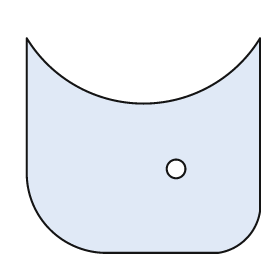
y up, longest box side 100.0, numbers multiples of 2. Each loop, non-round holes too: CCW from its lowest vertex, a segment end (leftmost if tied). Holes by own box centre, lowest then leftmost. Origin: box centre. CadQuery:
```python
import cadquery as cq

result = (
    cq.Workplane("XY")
    .moveTo(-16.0, -46.0)
    .lineTo(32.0, -46.0)
    .threePointArc((44.0, -40.0), (50.0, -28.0))
    .lineTo(50.0, 46.0)
    .threePointArc((0.0, 18.0), (-50.0, 46.0))
    .lineTo(-50.0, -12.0)
    .threePointArc((-40.0, -36.0), (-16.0, -46.0))
    .close()
    .moveTo(14.0, -10.0)
    .circle(4.0)
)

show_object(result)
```